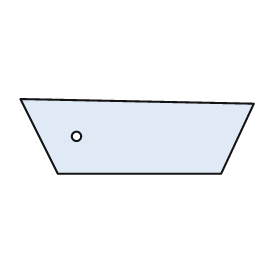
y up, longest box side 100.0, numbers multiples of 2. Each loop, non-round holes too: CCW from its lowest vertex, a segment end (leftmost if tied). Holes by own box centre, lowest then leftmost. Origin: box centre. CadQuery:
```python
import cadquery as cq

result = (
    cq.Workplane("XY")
    .moveTo(-34.0, -16.0)
    .lineTo(36.0, -16.0)
    .lineTo(50.0, 14.0)
    .lineTo(-50.0, 16.0)
    .close()
    .moveTo(-26.0, 0.0)
    .circle(2.0)
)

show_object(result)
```